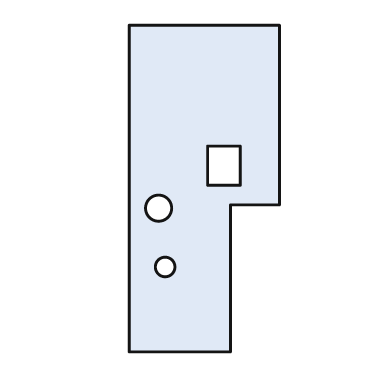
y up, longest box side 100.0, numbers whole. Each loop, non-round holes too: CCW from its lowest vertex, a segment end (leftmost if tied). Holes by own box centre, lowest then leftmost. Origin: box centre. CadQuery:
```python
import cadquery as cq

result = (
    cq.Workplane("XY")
    .moveTo(-23.0, -50.0)
    .lineTo(8.0, -50.0)
    .lineTo(8.0, -5.0)
    .lineTo(23.0, -5.0)
    .lineTo(23.0, 50.0)
    .lineTo(-23.0, 50.0)
    .close()
    .moveTo(-12.0, -24.0)
    .circle(3.0)
    .moveTo(-14.0, -6.0)
    .circle(4.0)
    .moveTo(1.0, 1.0)
    .lineTo(11.0, 1.0)
    .lineTo(11.0, 13.0)
    .lineTo(1.0, 13.0)
    .close()
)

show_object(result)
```